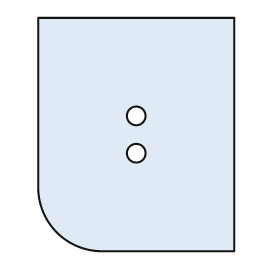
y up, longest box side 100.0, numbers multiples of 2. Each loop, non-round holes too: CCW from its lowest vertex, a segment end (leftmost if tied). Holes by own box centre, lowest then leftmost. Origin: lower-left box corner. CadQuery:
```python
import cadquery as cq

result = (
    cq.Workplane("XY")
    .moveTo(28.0, 0.0)
    .lineTo(84.0, 0.0)
    .lineTo(84.0, 100.0)
    .lineTo(0.0, 100.0)
    .lineTo(0.0, 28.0)
    .threePointArc((8.0, 8.0), (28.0, 0.0))
    .close()
    .moveTo(42.0, 42.0)
    .circle(4.0)
    .moveTo(42.0, 58.0)
    .circle(4.0)
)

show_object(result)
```